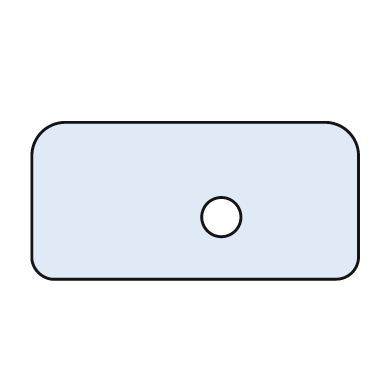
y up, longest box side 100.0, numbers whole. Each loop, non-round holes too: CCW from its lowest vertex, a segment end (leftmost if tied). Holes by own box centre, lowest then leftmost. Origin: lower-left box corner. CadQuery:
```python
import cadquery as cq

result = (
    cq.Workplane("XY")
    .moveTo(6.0, 0.0)
    .lineTo(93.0, 0.0)
    .threePointArc((98.0, 2.0), (100.0, 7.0))
    .lineTo(100.0, 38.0)
    .threePointArc((97.0, 45.0), (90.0, 48.0))
    .lineTo(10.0, 48.0)
    .threePointArc((3.0, 45.0), (0.0, 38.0))
    .lineTo(0.0, 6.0)
    .threePointArc((2.0, 2.0), (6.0, 0.0))
    .close()
    .moveTo(58.0, 19.0)
    .circle(6.0)
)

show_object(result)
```